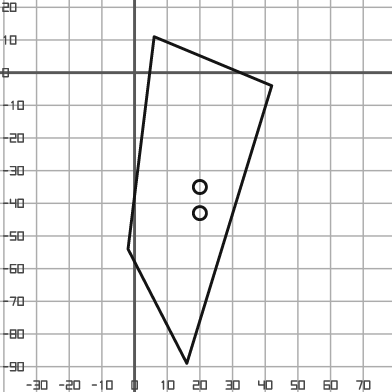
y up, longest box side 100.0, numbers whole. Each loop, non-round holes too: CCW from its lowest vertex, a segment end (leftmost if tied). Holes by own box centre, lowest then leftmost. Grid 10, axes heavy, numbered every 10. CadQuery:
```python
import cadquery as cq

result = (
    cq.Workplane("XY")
    .moveTo(16.0, -89.0)
    .lineTo(42.0, -4.0)
    .lineTo(6.0, 11.0)
    .lineTo(-2.0, -54.0)
    .close()
    .moveTo(20.0, -43.0)
    .circle(2.0)
    .moveTo(20.0, -35.0)
    .circle(2.0)
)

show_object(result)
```